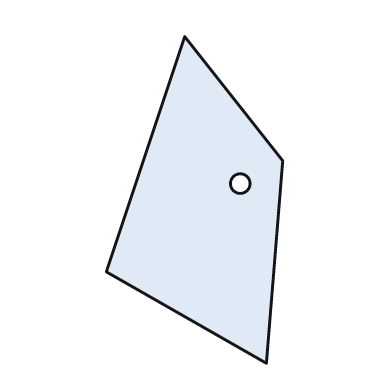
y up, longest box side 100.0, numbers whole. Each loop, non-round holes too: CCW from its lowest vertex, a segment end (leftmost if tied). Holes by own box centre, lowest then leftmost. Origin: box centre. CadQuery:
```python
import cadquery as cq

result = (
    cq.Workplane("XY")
    .moveTo(22.0, -50.0)
    .lineTo(27.0, 12.0)
    .lineTo(-3.0, 50.0)
    .lineTo(-27.0, -22.0)
    .close()
    .moveTo(14.0, 5.0)
    .circle(3.0)
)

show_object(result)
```